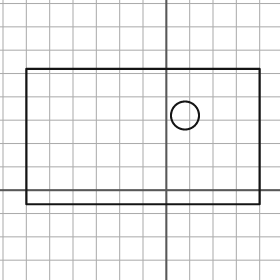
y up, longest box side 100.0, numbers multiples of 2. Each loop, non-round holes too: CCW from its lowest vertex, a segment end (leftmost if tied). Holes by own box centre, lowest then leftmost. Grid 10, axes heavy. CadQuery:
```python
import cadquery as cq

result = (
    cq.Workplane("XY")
    .moveTo(-60.0, -6.0)
    .lineTo(40.0, -6.0)
    .lineTo(40.0, 52.0)
    .lineTo(-60.0, 52.0)
    .close()
    .moveTo(8.0, 32.0)
    .circle(6.0)
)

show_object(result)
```